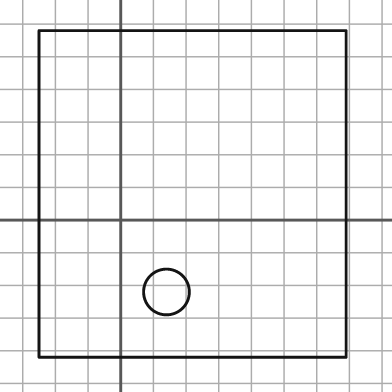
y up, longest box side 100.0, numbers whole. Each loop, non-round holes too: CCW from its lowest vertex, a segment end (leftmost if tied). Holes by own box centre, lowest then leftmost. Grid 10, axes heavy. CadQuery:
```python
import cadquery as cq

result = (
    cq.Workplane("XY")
    .moveTo(-25.0, -42.0)
    .lineTo(69.0, -42.0)
    .lineTo(69.0, 58.0)
    .lineTo(-25.0, 58.0)
    .close()
    .moveTo(14.0, -22.0)
    .circle(7.0)
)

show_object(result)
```